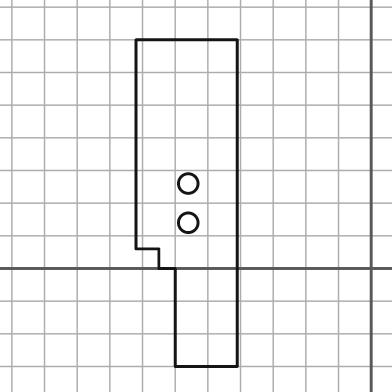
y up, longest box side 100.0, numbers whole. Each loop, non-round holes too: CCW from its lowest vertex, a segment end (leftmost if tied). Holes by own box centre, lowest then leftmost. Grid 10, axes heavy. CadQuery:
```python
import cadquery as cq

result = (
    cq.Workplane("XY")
    .moveTo(-60.0, -30.0)
    .lineTo(-41.0, -30.0)
    .lineTo(-41.0, 70.0)
    .lineTo(-72.0, 70.0)
    .lineTo(-72.0, 6.0)
    .lineTo(-65.0, 6.0)
    .lineTo(-65.0, 0.0)
    .lineTo(-60.0, 0.0)
    .close()
    .moveTo(-56.0, 14.0)
    .circle(3.0)
    .moveTo(-56.0, 26.0)
    .circle(3.0)
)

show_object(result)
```